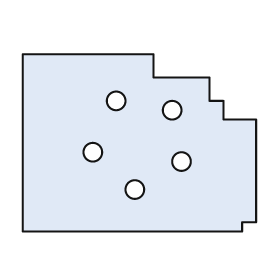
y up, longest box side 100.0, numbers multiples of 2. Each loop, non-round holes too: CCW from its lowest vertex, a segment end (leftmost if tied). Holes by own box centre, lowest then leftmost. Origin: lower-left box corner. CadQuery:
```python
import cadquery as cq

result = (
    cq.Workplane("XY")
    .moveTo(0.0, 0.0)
    .lineTo(94.0, 0.0)
    .lineTo(94.0, 4.0)
    .lineTo(100.0, 4.0)
    .lineTo(100.0, 48.0)
    .lineTo(86.0, 48.0)
    .lineTo(86.0, 56.0)
    .lineTo(80.0, 56.0)
    .lineTo(80.0, 66.0)
    .lineTo(56.0, 66.0)
    .lineTo(56.0, 76.0)
    .lineTo(0.0, 76.0)
    .close()
    .moveTo(48.0, 18.0)
    .circle(4.0)
    .moveTo(68.0, 30.0)
    .circle(4.0)
    .moveTo(30.0, 34.0)
    .circle(4.0)
    .moveTo(64.0, 52.0)
    .circle(4.0)
    .moveTo(40.0, 56.0)
    .circle(4.0)
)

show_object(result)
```